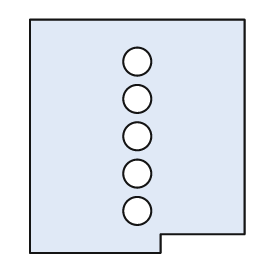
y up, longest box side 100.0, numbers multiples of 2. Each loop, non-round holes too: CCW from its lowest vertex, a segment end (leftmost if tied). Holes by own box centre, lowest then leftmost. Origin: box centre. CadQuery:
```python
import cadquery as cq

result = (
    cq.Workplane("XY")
    .moveTo(-46.0, -50.0)
    .lineTo(10.0, -50.0)
    .lineTo(10.0, -42.0)
    .lineTo(46.0, -42.0)
    .lineTo(46.0, 50.0)
    .lineTo(-46.0, 50.0)
    .close()
    .moveTo(0.0, -32.0)
    .circle(6.0)
    .moveTo(0.0, -16.0)
    .circle(6.0)
    .moveTo(0.0, 0.0)
    .circle(6.0)
    .moveTo(0.0, 16.0)
    .circle(6.0)
    .moveTo(0.0, 32.0)
    .circle(6.0)
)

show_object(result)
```